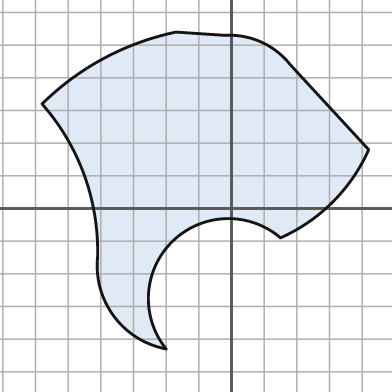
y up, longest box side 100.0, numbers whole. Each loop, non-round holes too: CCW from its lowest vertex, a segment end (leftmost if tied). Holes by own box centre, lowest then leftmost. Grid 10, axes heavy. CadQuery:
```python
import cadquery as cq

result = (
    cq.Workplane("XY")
    .moveTo(-20.0, -43.0)
    .threePointArc((-18.0, -10.0), (15.0, -9.0))
    .threePointArc((31.0, 2.0), (42.0, 18.0))
    .lineTo(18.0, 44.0)
    .threePointArc((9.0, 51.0), (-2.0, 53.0))
    .lineTo(-17.0, 54.0)
    .threePointArc((-39.0, 46.0), (-58.0, 32.0))
    .threePointArc((-45.0, 10.0), (-41.0, -15.0))
    .threePointArc((-36.0, -33.0), (-20.0, -43.0))
    .close()
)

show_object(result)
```